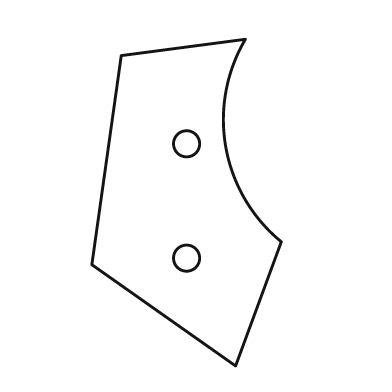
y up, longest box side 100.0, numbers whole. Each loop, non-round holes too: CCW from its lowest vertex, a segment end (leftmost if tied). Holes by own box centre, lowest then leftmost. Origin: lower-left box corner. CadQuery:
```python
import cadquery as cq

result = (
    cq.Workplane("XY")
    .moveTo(44.0, 0.0)
    .lineTo(58.0, 38.0)
    .threePointArc((41.0, 67.0), (47.0, 100.0))
    .lineTo(9.0, 95.0)
    .lineTo(0.0, 31.0)
    .close()
    .moveTo(29.0, 33.0)
    .circle(4.0)
    .moveTo(29.0, 68.0)
    .circle(4.0)
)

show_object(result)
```